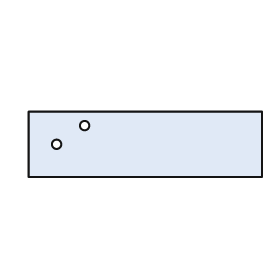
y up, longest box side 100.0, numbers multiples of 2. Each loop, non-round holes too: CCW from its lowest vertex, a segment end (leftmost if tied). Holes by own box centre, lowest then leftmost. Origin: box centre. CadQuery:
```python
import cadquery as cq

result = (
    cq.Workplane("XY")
    .moveTo(-50.0, -14.0)
    .lineTo(50.0, -14.0)
    .lineTo(50.0, 14.0)
    .lineTo(-50.0, 14.0)
    .close()
    .moveTo(-38.0, 0.0)
    .circle(2.0)
    .moveTo(-26.0, 8.0)
    .circle(2.0)
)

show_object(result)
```